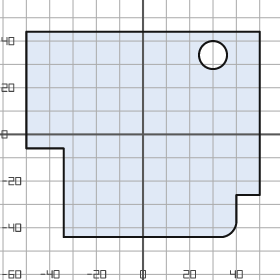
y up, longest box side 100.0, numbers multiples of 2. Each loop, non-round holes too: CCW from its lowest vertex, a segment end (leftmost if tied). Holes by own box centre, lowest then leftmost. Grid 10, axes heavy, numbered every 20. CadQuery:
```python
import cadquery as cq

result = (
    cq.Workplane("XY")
    .moveTo(-34.0, -44.0)
    .lineTo(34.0, -44.0)
    .threePointArc((38.0, -42.0), (40.0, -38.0))
    .lineTo(40.0, -26.0)
    .lineTo(50.0, -26.0)
    .lineTo(50.0, 44.0)
    .lineTo(-50.0, 44.0)
    .lineTo(-50.0, -6.0)
    .lineTo(-34.0, -6.0)
    .close()
    .moveTo(30.0, 34.0)
    .circle(6.0)
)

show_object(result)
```